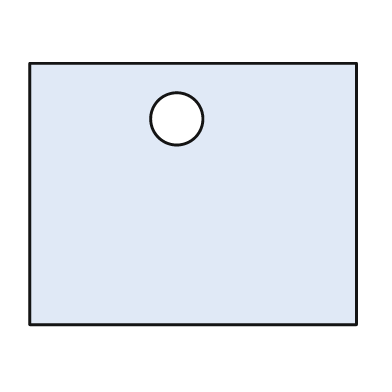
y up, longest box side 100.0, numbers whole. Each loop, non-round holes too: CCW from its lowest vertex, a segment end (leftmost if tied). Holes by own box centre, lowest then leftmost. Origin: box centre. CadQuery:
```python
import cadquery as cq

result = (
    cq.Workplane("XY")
    .moveTo(-50.0, -40.0)
    .lineTo(50.0, -40.0)
    .lineTo(50.0, 40.0)
    .lineTo(-50.0, 40.0)
    .close()
    .moveTo(-5.0, 23.0)
    .circle(8.0)
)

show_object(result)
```